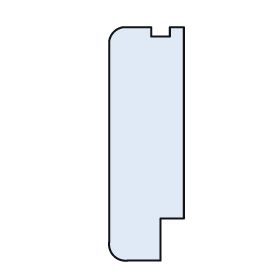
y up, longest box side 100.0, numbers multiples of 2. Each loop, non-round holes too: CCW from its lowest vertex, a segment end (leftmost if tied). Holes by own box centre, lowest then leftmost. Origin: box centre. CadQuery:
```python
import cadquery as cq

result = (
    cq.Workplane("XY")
    .moveTo(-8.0, -50.0)
    .lineTo(6.0, -50.0)
    .lineTo(6.0, -32.0)
    .lineTo(16.0, -32.0)
    .lineTo(16.0, 50.0)
    .lineTo(10.0, 50.0)
    .lineTo(10.0, 46.0)
    .lineTo(2.0, 46.0)
    .lineTo(2.0, 50.0)
    .lineTo(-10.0, 50.0)
    .threePointArc((-14.0, 48.0), (-16.0, 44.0))
    .lineTo(-16.0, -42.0)
    .threePointArc((-14.0, -48.0), (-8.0, -50.0))
    .close()
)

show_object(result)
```